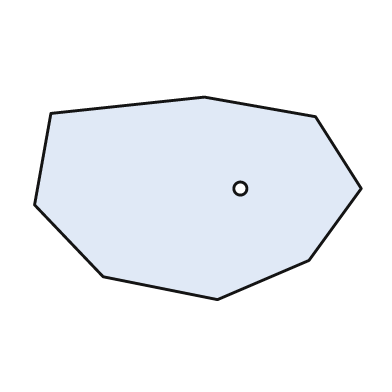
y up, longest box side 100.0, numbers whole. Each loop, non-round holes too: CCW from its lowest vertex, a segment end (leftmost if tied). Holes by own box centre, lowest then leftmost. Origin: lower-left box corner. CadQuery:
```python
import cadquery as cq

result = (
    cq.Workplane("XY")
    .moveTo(56.0, 0.0)
    .lineTo(84.0, 12.0)
    .lineTo(100.0, 34.0)
    .lineTo(86.0, 56.0)
    .lineTo(52.0, 62.0)
    .lineTo(5.0, 57.0)
    .lineTo(0.0, 29.0)
    .lineTo(21.0, 7.0)
    .close()
    .moveTo(63.0, 34.0)
    .circle(2.0)
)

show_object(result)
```